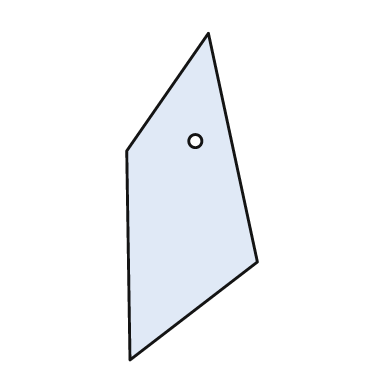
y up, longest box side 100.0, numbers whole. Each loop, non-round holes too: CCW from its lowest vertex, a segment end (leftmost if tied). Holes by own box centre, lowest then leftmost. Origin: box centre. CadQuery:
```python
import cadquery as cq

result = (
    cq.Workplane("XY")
    .moveTo(-19.0, -50.0)
    .lineTo(20.0, -20.0)
    .lineTo(5.0, 50.0)
    .lineTo(-20.0, 14.0)
    .close()
    .moveTo(1.0, 17.0)
    .circle(2.0)
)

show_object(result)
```